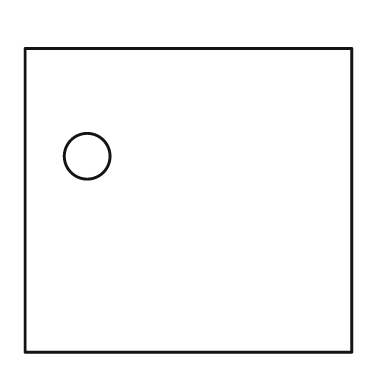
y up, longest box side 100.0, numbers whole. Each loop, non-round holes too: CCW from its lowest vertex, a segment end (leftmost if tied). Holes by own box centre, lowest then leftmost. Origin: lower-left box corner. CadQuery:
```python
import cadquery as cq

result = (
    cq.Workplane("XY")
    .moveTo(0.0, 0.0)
    .lineTo(100.0, 0.0)
    .lineTo(100.0, 93.0)
    .lineTo(0.0, 93.0)
    .close()
    .moveTo(19.0, 60.0)
    .circle(7.0)
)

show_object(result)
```